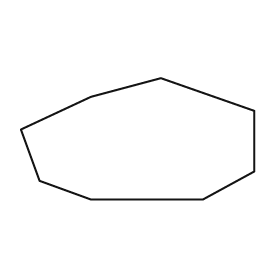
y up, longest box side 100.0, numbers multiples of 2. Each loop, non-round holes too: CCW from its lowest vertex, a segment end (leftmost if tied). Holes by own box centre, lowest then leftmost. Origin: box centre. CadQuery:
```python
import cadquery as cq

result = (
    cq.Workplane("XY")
    .moveTo(-20.0, -26.0)
    .lineTo(28.0, -26.0)
    .lineTo(50.0, -14.0)
    .lineTo(50.0, 12.0)
    .lineTo(10.0, 26.0)
    .lineTo(-20.0, 18.0)
    .lineTo(-50.0, 4.0)
    .lineTo(-42.0, -18.0)
    .close()
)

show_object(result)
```